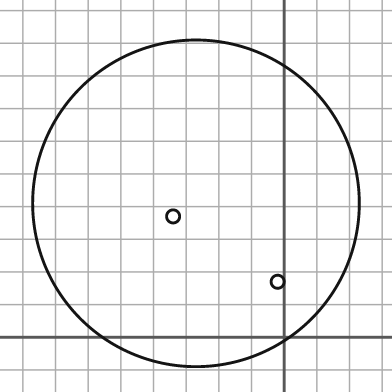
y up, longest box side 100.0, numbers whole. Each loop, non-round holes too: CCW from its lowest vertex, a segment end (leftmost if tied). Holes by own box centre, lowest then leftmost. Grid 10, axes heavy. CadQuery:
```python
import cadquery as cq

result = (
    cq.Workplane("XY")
    .moveTo(-27.0, 41.0)
    .circle(50.0)
    .moveTo(-2.0, 17.0)
    .circle(2.0)
    .moveTo(-34.0, 37.0)
    .circle(2.0)
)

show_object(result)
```